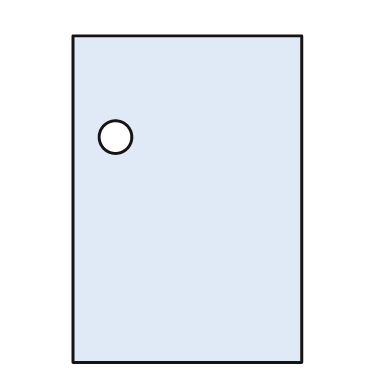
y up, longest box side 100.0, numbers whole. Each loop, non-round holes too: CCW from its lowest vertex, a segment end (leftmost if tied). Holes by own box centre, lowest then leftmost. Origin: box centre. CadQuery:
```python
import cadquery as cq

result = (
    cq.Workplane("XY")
    .moveTo(-35.0, -50.0)
    .lineTo(35.0, -50.0)
    .lineTo(35.0, 50.0)
    .lineTo(-35.0, 50.0)
    .close()
    .moveTo(-22.0, 19.0)
    .circle(5.0)
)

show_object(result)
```